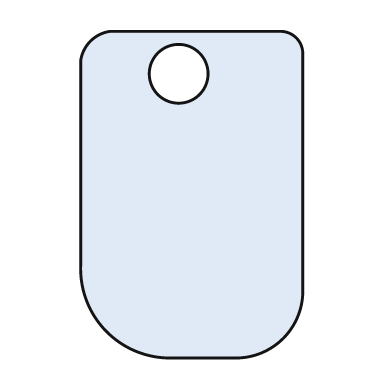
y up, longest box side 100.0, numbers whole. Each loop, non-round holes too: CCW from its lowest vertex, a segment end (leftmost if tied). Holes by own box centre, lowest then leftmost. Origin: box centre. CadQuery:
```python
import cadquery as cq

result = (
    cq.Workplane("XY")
    .moveTo(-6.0, -50.0)
    .lineTo(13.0, -50.0)
    .threePointArc((28.0, -44.0), (34.0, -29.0))
    .lineTo(34.0, 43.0)
    .threePointArc((32.0, 48.0), (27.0, 50.0))
    .lineTo(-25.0, 50.0)
    .threePointArc((-31.0, 47.0), (-34.0, 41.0))
    .lineTo(-34.0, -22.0)
    .threePointArc((-26.0, -42.0), (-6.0, -50.0))
    .close()
    .moveTo(-4.0, 37.0)
    .circle(9.0)
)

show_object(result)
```